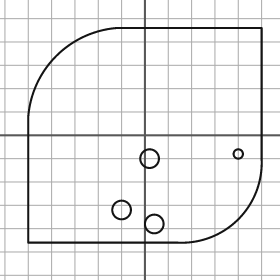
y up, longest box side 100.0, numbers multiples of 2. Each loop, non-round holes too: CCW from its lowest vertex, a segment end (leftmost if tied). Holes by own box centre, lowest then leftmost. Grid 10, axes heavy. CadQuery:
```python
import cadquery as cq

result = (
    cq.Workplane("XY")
    .moveTo(-50.0, -46.0)
    .lineTo(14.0, -46.0)
    .threePointArc((40.0, -36.0), (50.0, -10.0))
    .lineTo(50.0, 46.0)
    .lineTo(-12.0, 46.0)
    .threePointArc((-38.0, 34.0), (-50.0, 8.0))
    .close()
    .moveTo(4.0, -38.0)
    .circle(4.0)
    .moveTo(-10.0, -32.0)
    .circle(4.0)
    .moveTo(2.0, -10.0)
    .circle(4.0)
    .moveTo(40.0, -8.0)
    .circle(2.0)
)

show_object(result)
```